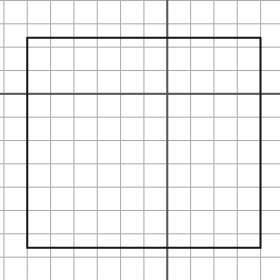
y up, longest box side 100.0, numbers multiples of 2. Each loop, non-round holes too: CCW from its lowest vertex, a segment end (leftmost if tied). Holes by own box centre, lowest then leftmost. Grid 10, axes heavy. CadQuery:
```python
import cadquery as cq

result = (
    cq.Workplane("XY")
    .moveTo(-60.0, -66.0)
    .lineTo(40.0, -66.0)
    .lineTo(40.0, 24.0)
    .lineTo(-60.0, 24.0)
    .close()
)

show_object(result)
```